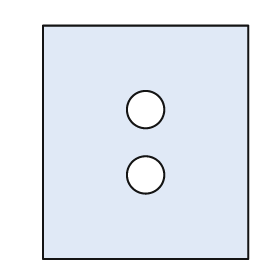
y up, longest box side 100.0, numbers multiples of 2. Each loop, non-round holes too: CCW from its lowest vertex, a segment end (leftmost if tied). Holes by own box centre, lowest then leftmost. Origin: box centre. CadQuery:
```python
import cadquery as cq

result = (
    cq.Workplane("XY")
    .moveTo(-44.0, -50.0)
    .lineTo(44.0, -50.0)
    .lineTo(44.0, 50.0)
    .lineTo(-44.0, 50.0)
    .close()
    .moveTo(0.0, -14.0)
    .circle(8.0)
    .moveTo(0.0, 14.0)
    .circle(8.0)
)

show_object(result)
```